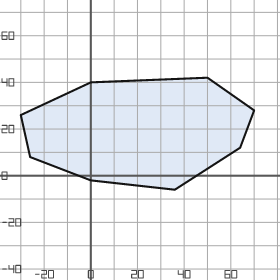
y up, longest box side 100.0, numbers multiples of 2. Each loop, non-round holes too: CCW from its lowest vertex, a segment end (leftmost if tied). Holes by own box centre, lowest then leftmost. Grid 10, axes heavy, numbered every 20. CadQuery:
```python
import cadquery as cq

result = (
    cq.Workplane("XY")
    .moveTo(36.0, -6.0)
    .lineTo(64.0, 12.0)
    .lineTo(70.0, 28.0)
    .lineTo(50.0, 42.0)
    .lineTo(0.0, 40.0)
    .lineTo(-30.0, 26.0)
    .lineTo(-26.0, 8.0)
    .lineTo(0.0, -2.0)
    .close()
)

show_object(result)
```